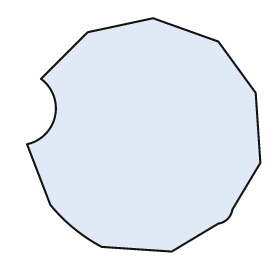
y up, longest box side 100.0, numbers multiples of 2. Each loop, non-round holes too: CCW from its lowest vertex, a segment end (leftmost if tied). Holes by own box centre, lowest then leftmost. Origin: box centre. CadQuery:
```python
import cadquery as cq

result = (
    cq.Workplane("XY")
    .moveTo(12.0, -50.0)
    .lineTo(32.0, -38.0)
    .threePointArc((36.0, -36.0), (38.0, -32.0))
    .lineTo(50.0, -12.0)
    .lineTo(48.0, 18.0)
    .lineTo(32.0, 40.0)
    .lineTo(4.0, 50.0)
    .lineTo(-24.0, 44.0)
    .lineTo(-44.0, 24.0)
    .threePointArc((-38.0, 8.0), (-50.0, -4.0))
    .lineTo(-40.0, -30.0)
    .threePointArc((-30.0, -40.0), (-18.0, -48.0))
    .close()
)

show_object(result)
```